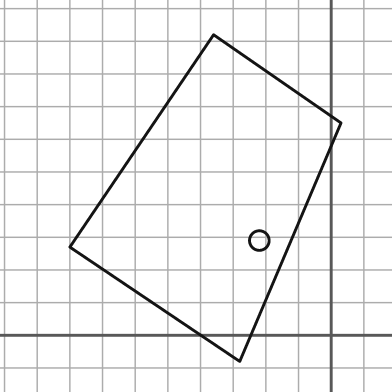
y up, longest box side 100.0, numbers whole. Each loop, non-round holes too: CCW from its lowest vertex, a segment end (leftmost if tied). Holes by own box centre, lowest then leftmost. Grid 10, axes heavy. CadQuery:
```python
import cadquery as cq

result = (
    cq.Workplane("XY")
    .moveTo(-28.0, -8.0)
    .lineTo(3.0, 65.0)
    .lineTo(-36.0, 92.0)
    .lineTo(-80.0, 27.0)
    .close()
    .moveTo(-22.0, 29.0)
    .circle(3.0)
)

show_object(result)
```